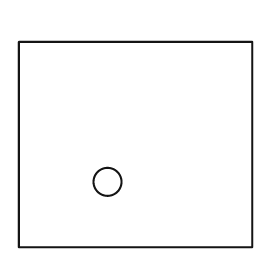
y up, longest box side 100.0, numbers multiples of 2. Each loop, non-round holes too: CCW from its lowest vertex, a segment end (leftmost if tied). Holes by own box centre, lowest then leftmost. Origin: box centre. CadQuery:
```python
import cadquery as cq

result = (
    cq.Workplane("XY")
    .moveTo(-50.0, -44.0)
    .lineTo(50.0, -44.0)
    .lineTo(50.0, 44.0)
    .lineTo(-50.0, 44.0)
    .close()
    .moveTo(-12.0, -16.0)
    .circle(6.0)
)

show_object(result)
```